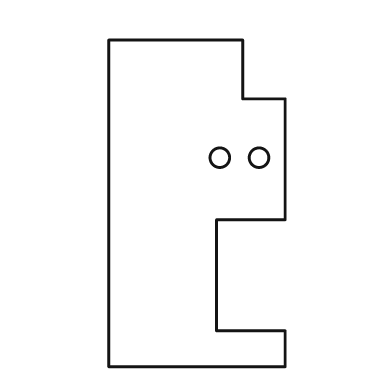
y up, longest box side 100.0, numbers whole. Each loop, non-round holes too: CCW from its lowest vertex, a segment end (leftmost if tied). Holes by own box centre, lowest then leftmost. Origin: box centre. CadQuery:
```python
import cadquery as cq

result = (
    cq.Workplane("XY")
    .moveTo(-27.0, -50.0)
    .lineTo(27.0, -50.0)
    .lineTo(27.0, -39.0)
    .lineTo(6.0, -39.0)
    .lineTo(6.0, -5.0)
    .lineTo(27.0, -5.0)
    .lineTo(27.0, 32.0)
    .lineTo(14.0, 32.0)
    .lineTo(14.0, 50.0)
    .lineTo(-27.0, 50.0)
    .close()
    .moveTo(7.0, 14.0)
    .circle(3.0)
    .moveTo(19.0, 14.0)
    .circle(3.0)
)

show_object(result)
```